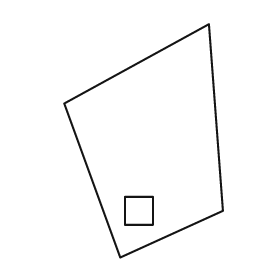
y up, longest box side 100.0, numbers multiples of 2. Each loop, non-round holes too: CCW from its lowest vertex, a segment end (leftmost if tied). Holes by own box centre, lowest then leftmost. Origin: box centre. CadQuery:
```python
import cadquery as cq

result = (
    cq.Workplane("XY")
    .moveTo(-10.0, -50.0)
    .lineTo(34.0, -30.0)
    .lineTo(28.0, 50.0)
    .lineTo(-34.0, 16.0)
    .close()
    .moveTo(-8.0, -36.0)
    .lineTo(4.0, -36.0)
    .lineTo(4.0, -24.0)
    .lineTo(-8.0, -24.0)
    .close()
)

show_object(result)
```